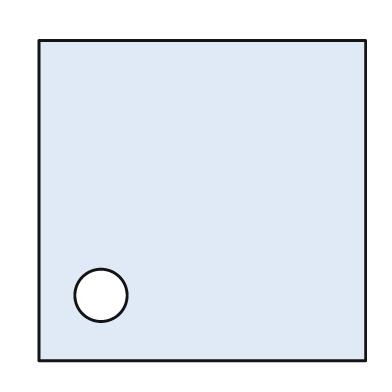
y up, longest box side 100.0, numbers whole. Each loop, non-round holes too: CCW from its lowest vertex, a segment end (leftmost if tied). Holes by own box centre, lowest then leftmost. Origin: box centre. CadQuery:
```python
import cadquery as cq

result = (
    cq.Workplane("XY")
    .moveTo(-50.0, -49.0)
    .lineTo(50.0, -49.0)
    .lineTo(50.0, 49.0)
    .lineTo(-50.0, 49.0)
    .close()
    .moveTo(-31.0, -29.0)
    .circle(8.0)
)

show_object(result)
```